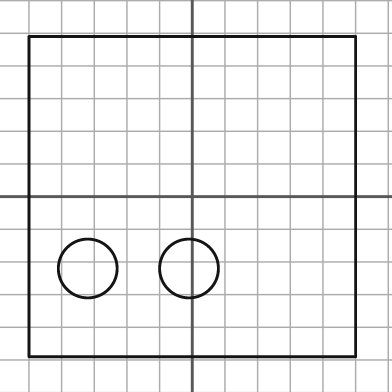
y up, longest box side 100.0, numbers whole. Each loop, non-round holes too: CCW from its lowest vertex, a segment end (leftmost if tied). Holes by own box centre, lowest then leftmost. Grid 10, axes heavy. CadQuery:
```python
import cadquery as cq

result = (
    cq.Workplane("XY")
    .moveTo(-50.0, -49.0)
    .lineTo(50.0, -49.0)
    .lineTo(50.0, 49.0)
    .lineTo(-50.0, 49.0)
    .close()
    .moveTo(-32.0, -22.0)
    .circle(9.0)
    .moveTo(-1.0, -22.0)
    .circle(9.0)
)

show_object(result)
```